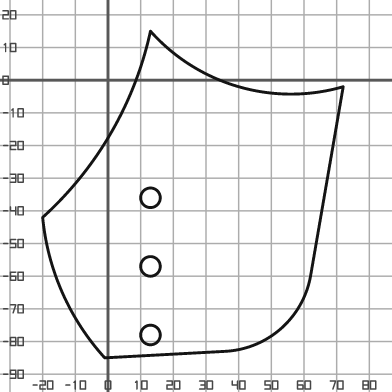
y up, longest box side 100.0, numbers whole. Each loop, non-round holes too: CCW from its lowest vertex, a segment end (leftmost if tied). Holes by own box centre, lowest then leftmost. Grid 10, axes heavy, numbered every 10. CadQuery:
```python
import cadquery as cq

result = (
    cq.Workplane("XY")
    .moveTo(-1.0, -85.0)
    .lineTo(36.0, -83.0)
    .threePointArc((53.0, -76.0), (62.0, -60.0))
    .lineTo(72.0, -2.0)
    .threePointArc((40.0, -2.0), (13.0, 15.0))
    .threePointArc((1.0, -16.0), (-20.0, -42.0))
    .threePointArc((-14.0, -65.0), (-1.0, -85.0))
    .close()
    .moveTo(13.0, -78.0)
    .circle(3.0)
    .moveTo(13.0, -57.0)
    .circle(3.0)
    .moveTo(13.0, -36.0)
    .circle(3.0)
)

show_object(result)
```